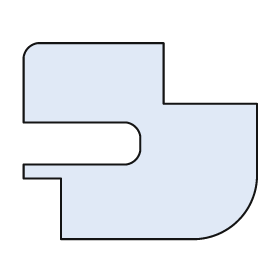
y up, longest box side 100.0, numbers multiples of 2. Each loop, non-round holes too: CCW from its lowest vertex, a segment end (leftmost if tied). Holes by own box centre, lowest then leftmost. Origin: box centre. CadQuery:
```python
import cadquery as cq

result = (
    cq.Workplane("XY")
    .moveTo(-34.0, -42.0)
    .lineTo(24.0, -42.0)
    .threePointArc((42.0, -34.0), (50.0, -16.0))
    .lineTo(50.0, 16.0)
    .lineTo(10.0, 16.0)
    .lineTo(10.0, 42.0)
    .lineTo(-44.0, 42.0)
    .threePointArc((-48.0, 40.0), (-50.0, 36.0))
    .lineTo(-50.0, 8.0)
    .lineTo(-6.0, 8.0)
    .threePointArc((-2.0, 6.0), (0.0, 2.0))
    .lineTo(0.0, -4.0)
    .threePointArc((-2.0, -8.0), (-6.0, -10.0))
    .lineTo(-50.0, -10.0)
    .lineTo(-50.0, -16.0)
    .lineTo(-34.0, -16.0)
    .close()
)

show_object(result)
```